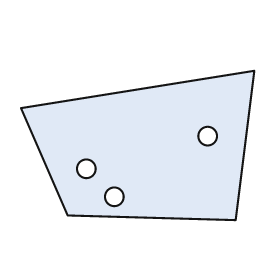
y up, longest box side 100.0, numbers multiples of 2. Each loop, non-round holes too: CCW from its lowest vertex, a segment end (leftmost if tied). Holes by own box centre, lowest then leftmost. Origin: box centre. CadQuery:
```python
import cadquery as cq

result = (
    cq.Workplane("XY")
    .moveTo(42.0, -32.0)
    .lineTo(50.0, 32.0)
    .lineTo(-50.0, 16.0)
    .lineTo(-30.0, -30.0)
    .close()
    .moveTo(-10.0, -22.0)
    .circle(4.0)
    .moveTo(-22.0, -10.0)
    .circle(4.0)
    .moveTo(30.0, 4.0)
    .circle(4.0)
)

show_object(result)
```